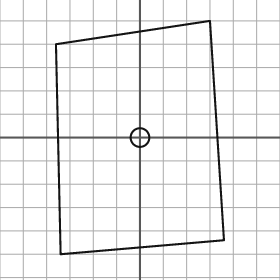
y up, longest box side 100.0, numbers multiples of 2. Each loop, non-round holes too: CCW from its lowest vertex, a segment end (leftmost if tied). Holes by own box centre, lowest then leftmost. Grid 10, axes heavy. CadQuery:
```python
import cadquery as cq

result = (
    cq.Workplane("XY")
    .moveTo(-34.0, -50.0)
    .lineTo(36.0, -44.0)
    .lineTo(30.0, 50.0)
    .lineTo(-36.0, 40.0)
    .close()
    .moveTo(0.0, 0.0)
    .circle(4.0)
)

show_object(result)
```